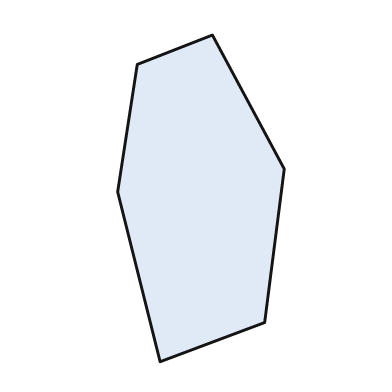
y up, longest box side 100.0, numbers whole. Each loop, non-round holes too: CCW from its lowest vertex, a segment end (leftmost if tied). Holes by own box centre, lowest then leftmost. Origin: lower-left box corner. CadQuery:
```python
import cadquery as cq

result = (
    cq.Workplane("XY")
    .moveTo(13.0, 0.0)
    .lineTo(45.0, 12.0)
    .lineTo(51.0, 59.0)
    .lineTo(29.0, 100.0)
    .lineTo(6.0, 91.0)
    .lineTo(0.0, 52.0)
    .close()
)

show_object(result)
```